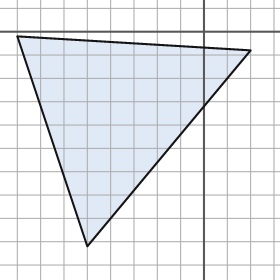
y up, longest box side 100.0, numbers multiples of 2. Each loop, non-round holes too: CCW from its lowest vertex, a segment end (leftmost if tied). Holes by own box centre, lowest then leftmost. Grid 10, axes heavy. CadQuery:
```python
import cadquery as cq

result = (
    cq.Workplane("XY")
    .moveTo(-50.0, -92.0)
    .lineTo(20.0, -8.0)
    .lineTo(-80.0, -2.0)
    .close()
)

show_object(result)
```